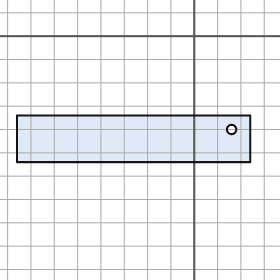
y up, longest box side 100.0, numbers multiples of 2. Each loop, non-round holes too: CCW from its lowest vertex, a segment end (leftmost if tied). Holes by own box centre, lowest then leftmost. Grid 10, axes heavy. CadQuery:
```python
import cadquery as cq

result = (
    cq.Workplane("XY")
    .moveTo(-76.0, -54.0)
    .lineTo(24.0, -54.0)
    .lineTo(24.0, -34.0)
    .lineTo(-76.0, -34.0)
    .close()
    .moveTo(16.0, -40.0)
    .circle(2.0)
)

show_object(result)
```